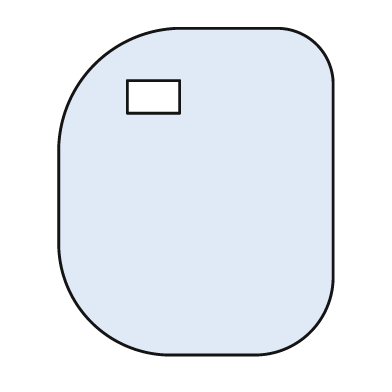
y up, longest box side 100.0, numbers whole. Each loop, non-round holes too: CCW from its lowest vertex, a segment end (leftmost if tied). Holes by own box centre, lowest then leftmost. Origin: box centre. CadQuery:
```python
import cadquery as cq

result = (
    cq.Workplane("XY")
    .moveTo(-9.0, -50.0)
    .lineTo(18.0, -50.0)
    .threePointArc((35.0, -43.0), (42.0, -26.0))
    .lineTo(42.0, 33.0)
    .threePointArc((37.0, 45.0), (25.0, 50.0))
    .lineTo(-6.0, 50.0)
    .threePointArc((-31.0, 39.0), (-42.0, 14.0))
    .lineTo(-42.0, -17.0)
    .threePointArc((-32.0, -40.0), (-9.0, -50.0))
    .close()
    .moveTo(-21.0, 24.0)
    .lineTo(-5.0, 24.0)
    .lineTo(-5.0, 34.0)
    .lineTo(-21.0, 34.0)
    .close()
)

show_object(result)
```